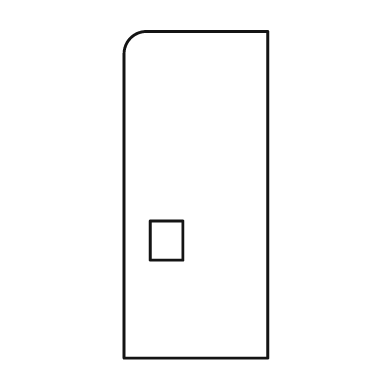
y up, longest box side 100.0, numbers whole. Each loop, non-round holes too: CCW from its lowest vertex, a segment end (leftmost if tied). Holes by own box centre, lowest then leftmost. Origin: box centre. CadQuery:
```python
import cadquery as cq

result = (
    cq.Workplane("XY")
    .moveTo(-22.0, -50.0)
    .lineTo(22.0, -50.0)
    .lineTo(22.0, 50.0)
    .lineTo(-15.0, 50.0)
    .threePointArc((-20.0, 48.0), (-22.0, 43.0))
    .close()
    .moveTo(-14.0, -20.0)
    .lineTo(-4.0, -20.0)
    .lineTo(-4.0, -8.0)
    .lineTo(-14.0, -8.0)
    .close()
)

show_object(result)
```